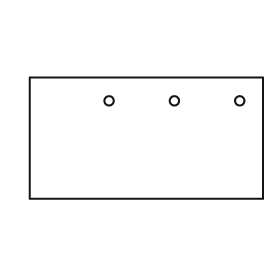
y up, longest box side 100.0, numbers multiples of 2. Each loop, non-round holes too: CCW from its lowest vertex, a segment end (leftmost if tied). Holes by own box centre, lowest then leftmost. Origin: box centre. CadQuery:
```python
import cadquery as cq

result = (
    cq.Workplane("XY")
    .moveTo(-50.0, -26.0)
    .lineTo(50.0, -26.0)
    .lineTo(50.0, 26.0)
    .lineTo(-50.0, 26.0)
    .close()
    .moveTo(-16.0, 16.0)
    .circle(2.0)
    .moveTo(12.0, 16.0)
    .circle(2.0)
    .moveTo(40.0, 16.0)
    .circle(2.0)
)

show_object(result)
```